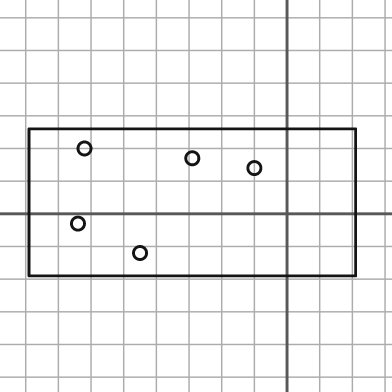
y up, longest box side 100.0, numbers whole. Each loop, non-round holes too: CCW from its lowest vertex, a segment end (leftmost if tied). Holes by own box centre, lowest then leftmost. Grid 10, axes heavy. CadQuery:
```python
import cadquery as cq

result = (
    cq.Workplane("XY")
    .moveTo(-79.0, -19.0)
    .lineTo(21.0, -19.0)
    .lineTo(21.0, 26.0)
    .lineTo(-79.0, 26.0)
    .close()
    .moveTo(-45.0, -12.0)
    .circle(2.0)
    .moveTo(-64.0, -3.0)
    .circle(2.0)
    .moveTo(-10.0, 14.0)
    .circle(2.0)
    .moveTo(-29.0, 17.0)
    .circle(2.0)
    .moveTo(-62.0, 20.0)
    .circle(2.0)
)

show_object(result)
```